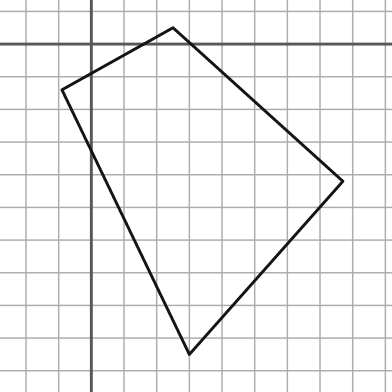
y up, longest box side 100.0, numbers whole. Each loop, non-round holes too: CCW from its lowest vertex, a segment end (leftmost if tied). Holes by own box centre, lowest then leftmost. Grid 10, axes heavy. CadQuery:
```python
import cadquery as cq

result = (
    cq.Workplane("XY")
    .moveTo(30.0, -95.0)
    .lineTo(77.0, -42.0)
    .lineTo(25.0, 5.0)
    .lineTo(-9.0, -14.0)
    .close()
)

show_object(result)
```